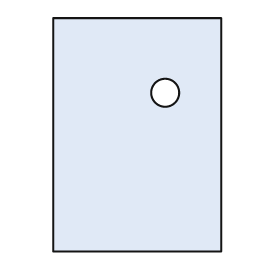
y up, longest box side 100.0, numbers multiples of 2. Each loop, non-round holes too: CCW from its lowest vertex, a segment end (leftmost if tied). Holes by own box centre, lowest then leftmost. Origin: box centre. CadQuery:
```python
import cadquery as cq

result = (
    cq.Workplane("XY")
    .moveTo(-36.0, -50.0)
    .lineTo(36.0, -50.0)
    .lineTo(36.0, 50.0)
    .lineTo(-36.0, 50.0)
    .close()
    .moveTo(12.0, 18.0)
    .circle(6.0)
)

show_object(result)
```